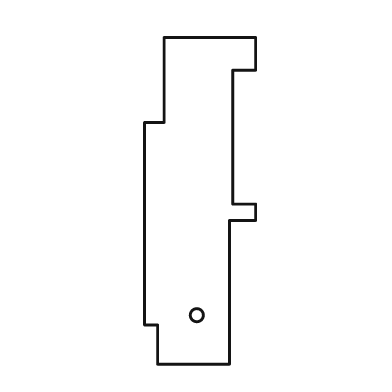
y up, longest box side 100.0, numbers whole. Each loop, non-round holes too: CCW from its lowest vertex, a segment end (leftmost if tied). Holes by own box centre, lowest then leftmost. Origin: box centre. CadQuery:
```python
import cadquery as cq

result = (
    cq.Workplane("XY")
    .moveTo(-13.0, -50.0)
    .lineTo(9.0, -50.0)
    .lineTo(9.0, -6.0)
    .lineTo(17.0, -6.0)
    .lineTo(17.0, -1.0)
    .lineTo(10.0, -1.0)
    .lineTo(10.0, 40.0)
    .lineTo(17.0, 40.0)
    .lineTo(17.0, 50.0)
    .lineTo(-11.0, 50.0)
    .lineTo(-11.0, 24.0)
    .lineTo(-17.0, 24.0)
    .lineTo(-17.0, -38.0)
    .lineTo(-13.0, -38.0)
    .close()
    .moveTo(-1.0, -35.0)
    .circle(2.0)
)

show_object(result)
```